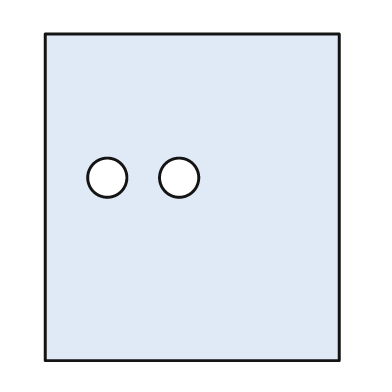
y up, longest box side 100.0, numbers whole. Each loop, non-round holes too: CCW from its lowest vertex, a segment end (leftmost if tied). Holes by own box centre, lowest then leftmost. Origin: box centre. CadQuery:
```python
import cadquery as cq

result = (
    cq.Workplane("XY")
    .moveTo(-45.0, -50.0)
    .lineTo(45.0, -50.0)
    .lineTo(45.0, 50.0)
    .lineTo(-45.0, 50.0)
    .close()
    .moveTo(-26.0, 6.0)
    .circle(6.0)
    .moveTo(-4.0, 6.0)
    .circle(6.0)
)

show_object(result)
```